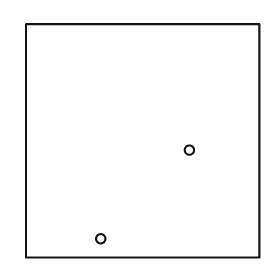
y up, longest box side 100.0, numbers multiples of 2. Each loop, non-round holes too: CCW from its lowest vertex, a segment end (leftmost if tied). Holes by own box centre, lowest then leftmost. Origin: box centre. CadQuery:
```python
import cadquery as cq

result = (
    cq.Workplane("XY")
    .moveTo(-50.0, -50.0)
    .lineTo(50.0, -50.0)
    .lineTo(50.0, 50.0)
    .lineTo(-50.0, 50.0)
    .close()
    .moveTo(-18.0, -42.0)
    .circle(2.0)
    .moveTo(20.0, -4.0)
    .circle(2.0)
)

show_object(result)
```